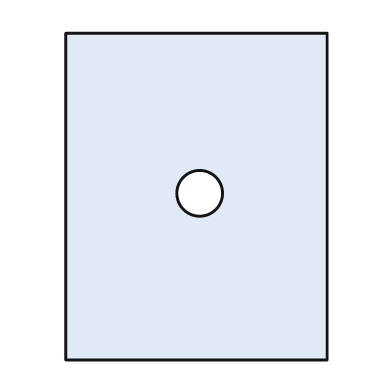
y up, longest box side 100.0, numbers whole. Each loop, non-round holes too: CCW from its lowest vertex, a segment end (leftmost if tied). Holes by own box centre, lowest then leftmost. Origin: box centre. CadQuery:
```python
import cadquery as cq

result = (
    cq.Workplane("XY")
    .moveTo(-40.0, -50.0)
    .lineTo(40.0, -50.0)
    .lineTo(40.0, 50.0)
    .lineTo(-40.0, 50.0)
    .close()
    .moveTo(1.0, 1.0)
    .circle(7.0)
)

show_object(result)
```